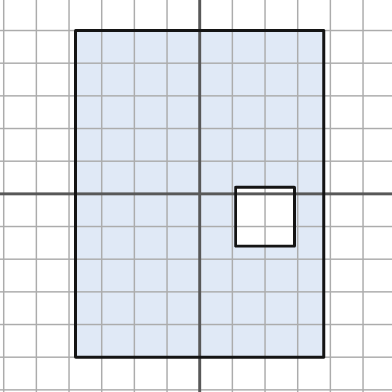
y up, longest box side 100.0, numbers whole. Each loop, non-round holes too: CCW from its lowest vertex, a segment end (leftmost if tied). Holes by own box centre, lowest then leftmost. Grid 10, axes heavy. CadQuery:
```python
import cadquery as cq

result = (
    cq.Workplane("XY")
    .moveTo(-38.0, -50.0)
    .lineTo(38.0, -50.0)
    .lineTo(38.0, 50.0)
    .lineTo(-38.0, 50.0)
    .close()
    .moveTo(11.0, -16.0)
    .lineTo(29.0, -16.0)
    .lineTo(29.0, 2.0)
    .lineTo(11.0, 2.0)
    .close()
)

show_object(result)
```